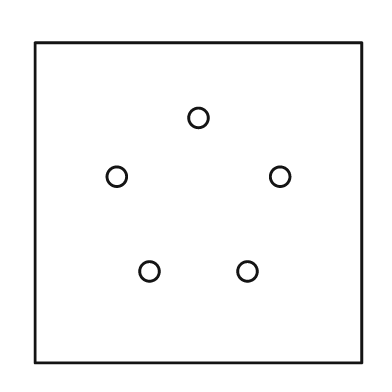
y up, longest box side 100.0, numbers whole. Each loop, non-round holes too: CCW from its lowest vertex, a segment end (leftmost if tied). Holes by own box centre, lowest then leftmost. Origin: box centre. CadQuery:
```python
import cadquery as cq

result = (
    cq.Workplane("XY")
    .moveTo(-50.0, -49.0)
    .lineTo(50.0, -49.0)
    .lineTo(50.0, 49.0)
    .lineTo(-50.0, 49.0)
    .close()
    .moveTo(-15.0, -21.0)
    .circle(3.0)
    .moveTo(15.0, -21.0)
    .circle(3.0)
    .moveTo(-25.0, 8.0)
    .circle(3.0)
    .moveTo(25.0, 8.0)
    .circle(3.0)
    .moveTo(0.0, 26.0)
    .circle(3.0)
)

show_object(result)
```